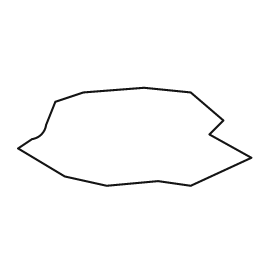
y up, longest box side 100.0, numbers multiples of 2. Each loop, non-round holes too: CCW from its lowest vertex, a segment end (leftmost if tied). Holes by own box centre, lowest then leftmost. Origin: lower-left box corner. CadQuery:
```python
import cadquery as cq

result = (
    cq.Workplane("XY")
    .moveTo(38.0, 0.0)
    .lineTo(60.0, 2.0)
    .lineTo(74.0, 0.0)
    .lineTo(100.0, 12.0)
    .lineTo(82.0, 22.0)
    .lineTo(88.0, 28.0)
    .lineTo(74.0, 40.0)
    .lineTo(54.0, 42.0)
    .lineTo(28.0, 40.0)
    .lineTo(16.0, 36.0)
    .lineTo(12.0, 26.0)
    .threePointArc((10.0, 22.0), (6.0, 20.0))
    .lineTo(0.0, 16.0)
    .lineTo(20.0, 4.0)
    .close()
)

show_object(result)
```